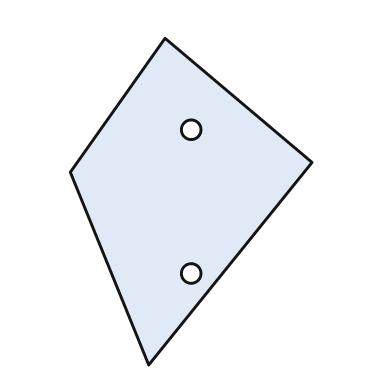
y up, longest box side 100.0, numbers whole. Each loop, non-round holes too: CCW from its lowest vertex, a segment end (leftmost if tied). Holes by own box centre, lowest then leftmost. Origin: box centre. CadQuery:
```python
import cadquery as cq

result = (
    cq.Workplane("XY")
    .moveTo(-13.0, -50.0)
    .lineTo(37.0, 12.0)
    .lineTo(-8.0, 50.0)
    .lineTo(-37.0, 9.0)
    .close()
    .moveTo(0.0, -22.0)
    .circle(3.0)
    .moveTo(0.0, 22.0)
    .circle(3.0)
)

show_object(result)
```